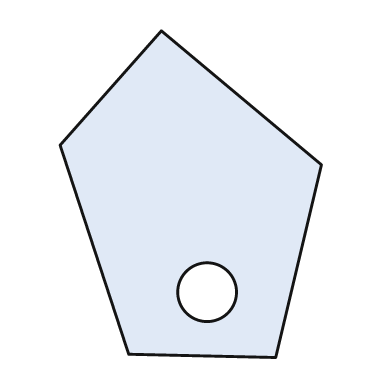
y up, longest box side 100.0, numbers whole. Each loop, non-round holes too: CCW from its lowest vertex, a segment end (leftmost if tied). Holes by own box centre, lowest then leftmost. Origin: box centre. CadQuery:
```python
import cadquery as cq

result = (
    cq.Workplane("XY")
    .moveTo(26.0, -50.0)
    .lineTo(40.0, 9.0)
    .lineTo(-9.0, 50.0)
    .lineTo(-40.0, 15.0)
    .lineTo(-19.0, -49.0)
    .close()
    .moveTo(5.0, -30.0)
    .circle(9.0)
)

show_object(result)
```